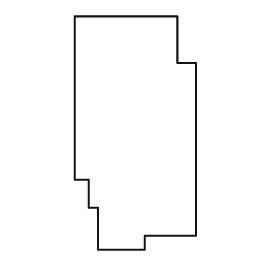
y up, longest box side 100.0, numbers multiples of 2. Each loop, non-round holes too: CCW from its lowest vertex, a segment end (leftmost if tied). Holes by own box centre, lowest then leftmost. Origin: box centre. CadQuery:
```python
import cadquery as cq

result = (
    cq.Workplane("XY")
    .moveTo(-16.0, -50.0)
    .lineTo(4.0, -50.0)
    .lineTo(4.0, -44.0)
    .lineTo(26.0, -44.0)
    .lineTo(26.0, 30.0)
    .lineTo(18.0, 30.0)
    .lineTo(18.0, 50.0)
    .lineTo(-26.0, 50.0)
    .lineTo(-26.0, -20.0)
    .lineTo(-20.0, -20.0)
    .lineTo(-20.0, -32.0)
    .lineTo(-16.0, -32.0)
    .close()
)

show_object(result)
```